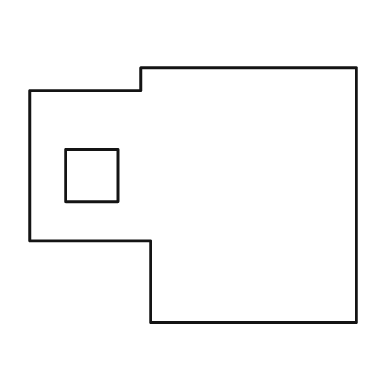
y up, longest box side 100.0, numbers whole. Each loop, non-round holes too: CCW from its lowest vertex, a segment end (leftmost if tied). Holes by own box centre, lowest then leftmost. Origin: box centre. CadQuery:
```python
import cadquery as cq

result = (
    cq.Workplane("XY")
    .moveTo(-13.0, -39.0)
    .lineTo(50.0, -39.0)
    .lineTo(50.0, 39.0)
    .lineTo(-16.0, 39.0)
    .lineTo(-16.0, 32.0)
    .lineTo(-50.0, 32.0)
    .lineTo(-50.0, -14.0)
    .lineTo(-13.0, -14.0)
    .close()
    .moveTo(-39.0, -2.0)
    .lineTo(-23.0, -2.0)
    .lineTo(-23.0, 14.0)
    .lineTo(-39.0, 14.0)
    .close()
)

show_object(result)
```